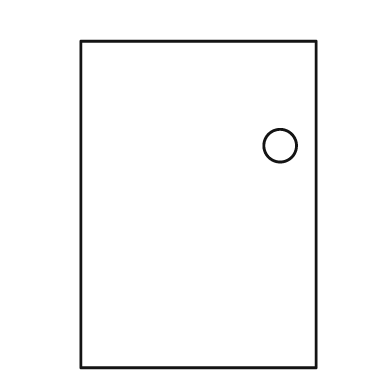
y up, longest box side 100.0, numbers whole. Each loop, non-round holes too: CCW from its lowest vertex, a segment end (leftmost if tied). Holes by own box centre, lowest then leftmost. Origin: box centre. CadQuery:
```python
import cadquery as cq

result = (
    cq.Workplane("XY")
    .moveTo(-36.0, -50.0)
    .lineTo(36.0, -50.0)
    .lineTo(36.0, 50.0)
    .lineTo(-36.0, 50.0)
    .close()
    .moveTo(25.0, 18.0)
    .circle(5.0)
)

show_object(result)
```